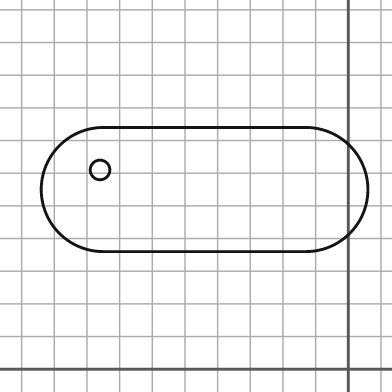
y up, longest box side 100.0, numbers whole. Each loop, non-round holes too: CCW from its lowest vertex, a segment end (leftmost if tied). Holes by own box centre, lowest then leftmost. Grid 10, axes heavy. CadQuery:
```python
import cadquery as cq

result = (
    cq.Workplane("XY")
    .moveTo(-75.0, 36.0)
    .lineTo(-13.0, 36.0)
    .threePointArc((6.0, 55.0), (-13.0, 74.0))
    .lineTo(-75.0, 74.0)
    .threePointArc((-94.0, 55.0), (-75.0, 36.0))
    .close()
    .moveTo(-76.0, 61.0)
    .circle(3.0)
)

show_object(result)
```